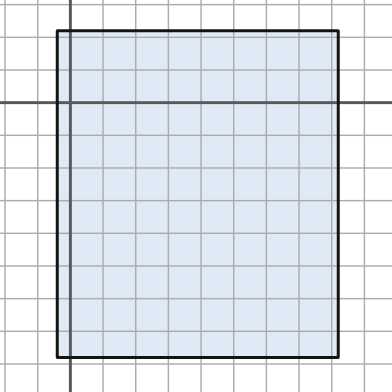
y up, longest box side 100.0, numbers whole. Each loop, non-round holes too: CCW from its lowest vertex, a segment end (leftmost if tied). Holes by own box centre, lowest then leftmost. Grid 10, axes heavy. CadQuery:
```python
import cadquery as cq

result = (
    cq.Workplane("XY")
    .moveTo(-4.0, -78.0)
    .lineTo(82.0, -78.0)
    .lineTo(82.0, 22.0)
    .lineTo(-4.0, 22.0)
    .close()
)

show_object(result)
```